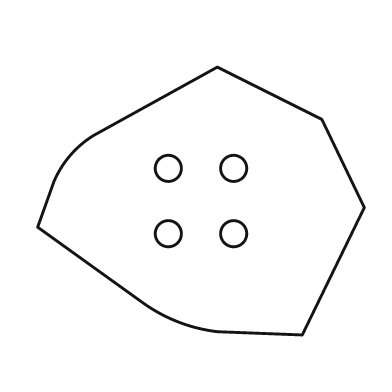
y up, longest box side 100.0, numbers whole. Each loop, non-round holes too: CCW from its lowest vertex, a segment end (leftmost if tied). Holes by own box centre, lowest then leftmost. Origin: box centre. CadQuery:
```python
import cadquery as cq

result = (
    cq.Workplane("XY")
    .moveTo(31.0, -41.0)
    .lineTo(50.0, -2.0)
    .lineTo(37.0, 25.0)
    .lineTo(5.0, 41.0)
    .lineTo(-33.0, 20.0)
    .threePointArc((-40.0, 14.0), (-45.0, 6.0))
    .lineTo(-50.0, -8.0)
    .lineTo(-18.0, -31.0)
    .threePointArc((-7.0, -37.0), (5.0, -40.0))
    .close()
    .moveTo(-10.0, -10.0)
    .circle(4.0)
    .moveTo(10.0, -10.0)
    .circle(4.0)
    .moveTo(-10.0, 10.0)
    .circle(4.0)
    .moveTo(10.0, 10.0)
    .circle(4.0)
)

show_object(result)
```